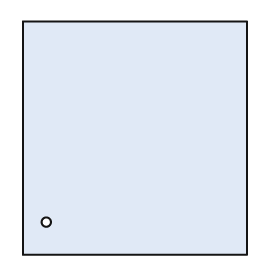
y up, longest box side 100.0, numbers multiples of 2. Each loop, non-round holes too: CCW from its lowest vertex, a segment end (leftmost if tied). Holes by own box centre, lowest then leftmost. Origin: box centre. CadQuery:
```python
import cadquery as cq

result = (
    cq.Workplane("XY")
    .moveTo(-48.0, -50.0)
    .lineTo(48.0, -50.0)
    .lineTo(48.0, 50.0)
    .lineTo(-48.0, 50.0)
    .close()
    .moveTo(-38.0, -36.0)
    .circle(2.0)
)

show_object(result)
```